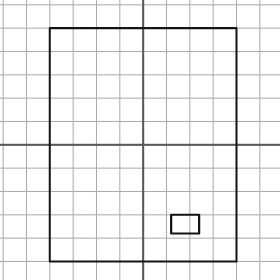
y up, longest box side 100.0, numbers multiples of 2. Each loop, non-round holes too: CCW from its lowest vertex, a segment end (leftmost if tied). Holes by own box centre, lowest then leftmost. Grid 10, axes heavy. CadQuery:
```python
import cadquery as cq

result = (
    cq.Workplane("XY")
    .moveTo(-40.0, -50.0)
    .lineTo(40.0, -50.0)
    .lineTo(40.0, 50.0)
    .lineTo(-40.0, 50.0)
    .close()
    .moveTo(12.0, -38.0)
    .lineTo(24.0, -38.0)
    .lineTo(24.0, -30.0)
    .lineTo(12.0, -30.0)
    .close()
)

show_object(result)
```